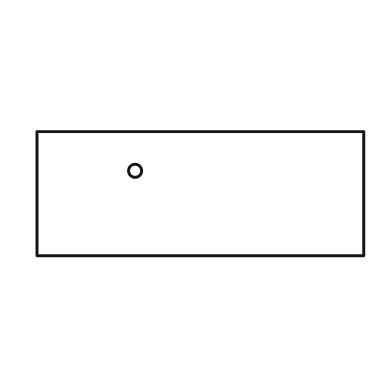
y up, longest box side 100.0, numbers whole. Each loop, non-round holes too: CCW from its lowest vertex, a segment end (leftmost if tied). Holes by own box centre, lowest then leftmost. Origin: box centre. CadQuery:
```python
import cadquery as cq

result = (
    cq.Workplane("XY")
    .moveTo(-50.0, -19.0)
    .lineTo(50.0, -19.0)
    .lineTo(50.0, 19.0)
    .lineTo(-50.0, 19.0)
    .close()
    .moveTo(-20.0, 7.0)
    .circle(2.0)
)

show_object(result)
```